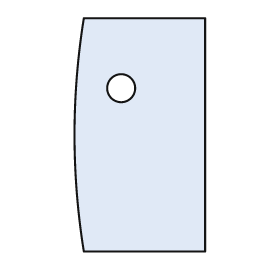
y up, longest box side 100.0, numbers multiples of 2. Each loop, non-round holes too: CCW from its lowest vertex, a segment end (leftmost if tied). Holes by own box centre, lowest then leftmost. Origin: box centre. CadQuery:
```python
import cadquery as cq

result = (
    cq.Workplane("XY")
    .moveTo(-24.0, -50.0)
    .lineTo(28.0, -50.0)
    .lineTo(28.0, 50.0)
    .lineTo(-24.0, 50.0)
    .threePointArc((-28.0, 0.0), (-24.0, -50.0))
    .close()
    .moveTo(-8.0, 20.0)
    .circle(6.0)
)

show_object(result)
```